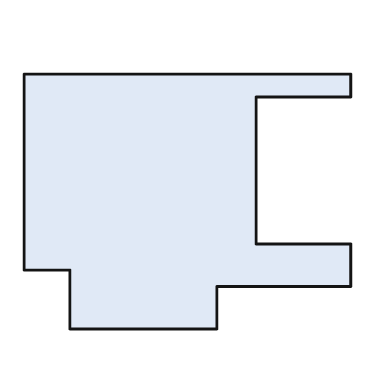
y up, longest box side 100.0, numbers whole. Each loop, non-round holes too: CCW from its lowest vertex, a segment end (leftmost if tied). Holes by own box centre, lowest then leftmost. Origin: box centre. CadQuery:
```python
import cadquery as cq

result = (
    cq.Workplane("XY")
    .moveTo(-36.0, -39.0)
    .lineTo(9.0, -39.0)
    .lineTo(9.0, -26.0)
    .lineTo(50.0, -26.0)
    .lineTo(50.0, -13.0)
    .lineTo(21.0, -13.0)
    .lineTo(21.0, 32.0)
    .lineTo(50.0, 32.0)
    .lineTo(50.0, 39.0)
    .lineTo(-50.0, 39.0)
    .lineTo(-50.0, -21.0)
    .lineTo(-36.0, -21.0)
    .close()
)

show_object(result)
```